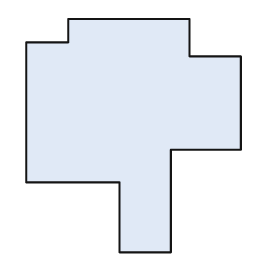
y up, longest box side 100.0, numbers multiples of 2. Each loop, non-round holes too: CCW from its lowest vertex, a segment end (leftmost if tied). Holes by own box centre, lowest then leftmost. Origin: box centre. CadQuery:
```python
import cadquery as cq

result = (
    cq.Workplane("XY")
    .moveTo(-6.0, -50.0)
    .lineTo(16.0, -50.0)
    .lineTo(16.0, -6.0)
    .lineTo(46.0, -6.0)
    .lineTo(46.0, 34.0)
    .lineTo(24.0, 34.0)
    .lineTo(24.0, 50.0)
    .lineTo(-28.0, 50.0)
    .lineTo(-28.0, 40.0)
    .lineTo(-46.0, 40.0)
    .lineTo(-46.0, -20.0)
    .lineTo(-6.0, -20.0)
    .close()
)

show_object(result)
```